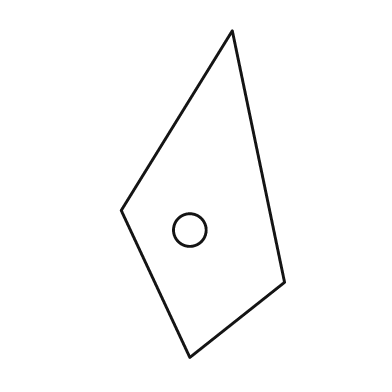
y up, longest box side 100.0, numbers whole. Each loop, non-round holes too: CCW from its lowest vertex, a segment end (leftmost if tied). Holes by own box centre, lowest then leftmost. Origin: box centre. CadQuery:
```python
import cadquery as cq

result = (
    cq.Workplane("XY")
    .moveTo(-4.0, -50.0)
    .lineTo(25.0, -27.0)
    .lineTo(9.0, 50.0)
    .lineTo(-25.0, -5.0)
    .close()
    .moveTo(-4.0, -11.0)
    .circle(5.0)
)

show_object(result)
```